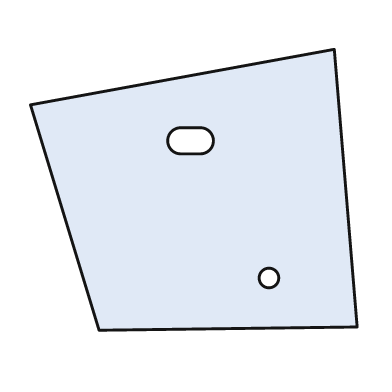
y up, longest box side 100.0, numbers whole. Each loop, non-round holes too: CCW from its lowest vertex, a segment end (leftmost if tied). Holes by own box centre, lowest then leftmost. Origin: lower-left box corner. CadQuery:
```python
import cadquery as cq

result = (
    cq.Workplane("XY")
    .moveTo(21.0, 0.0)
    .lineTo(100.0, 1.0)
    .lineTo(93.0, 86.0)
    .lineTo(0.0, 69.0)
    .close()
    .moveTo(73.0, 16.0)
    .circle(3.0)
    .moveTo(46.0, 54.0)
    .lineTo(52.0, 54.0)
    .threePointArc((56.0, 58.0), (52.0, 62.0))
    .lineTo(46.0, 62.0)
    .threePointArc((42.0, 58.0), (46.0, 54.0))
    .close()
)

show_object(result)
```